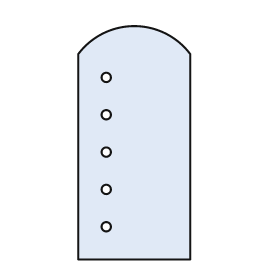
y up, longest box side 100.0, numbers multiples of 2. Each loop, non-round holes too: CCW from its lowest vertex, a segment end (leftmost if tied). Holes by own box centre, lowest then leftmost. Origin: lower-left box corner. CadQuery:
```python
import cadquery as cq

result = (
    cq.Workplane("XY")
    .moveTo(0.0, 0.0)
    .lineTo(48.0, 0.0)
    .lineTo(48.0, 88.0)
    .threePointArc((24.0, 100.0), (0.0, 88.0))
    .close()
    .moveTo(12.0, 14.0)
    .circle(2.0)
    .moveTo(12.0, 30.0)
    .circle(2.0)
    .moveTo(12.0, 46.0)
    .circle(2.0)
    .moveTo(12.0, 62.0)
    .circle(2.0)
    .moveTo(12.0, 78.0)
    .circle(2.0)
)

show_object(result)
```